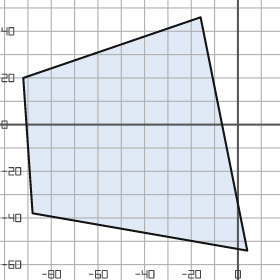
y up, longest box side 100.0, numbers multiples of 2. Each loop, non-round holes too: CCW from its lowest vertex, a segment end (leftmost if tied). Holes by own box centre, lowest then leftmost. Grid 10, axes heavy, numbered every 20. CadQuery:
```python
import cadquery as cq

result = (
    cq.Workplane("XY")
    .moveTo(4.0, -54.0)
    .lineTo(-16.0, 46.0)
    .lineTo(-92.0, 20.0)
    .lineTo(-88.0, -38.0)
    .close()
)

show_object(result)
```